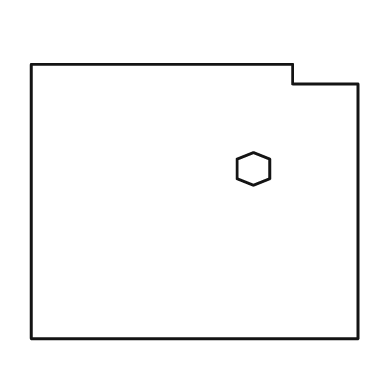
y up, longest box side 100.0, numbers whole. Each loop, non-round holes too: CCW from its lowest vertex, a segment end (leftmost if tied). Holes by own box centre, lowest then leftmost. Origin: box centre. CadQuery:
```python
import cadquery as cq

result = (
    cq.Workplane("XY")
    .moveTo(-50.0, -42.0)
    .lineTo(50.0, -42.0)
    .lineTo(50.0, 36.0)
    .lineTo(30.0, 36.0)
    .lineTo(30.0, 42.0)
    .lineTo(-50.0, 42.0)
    .close()
    .moveTo(18.0, 5.0)
    .lineTo(23.0, 7.0)
    .lineTo(23.0, 13.0)
    .lineTo(18.0, 15.0)
    .lineTo(13.0, 13.0)
    .lineTo(13.0, 7.0)
    .close()
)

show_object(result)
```